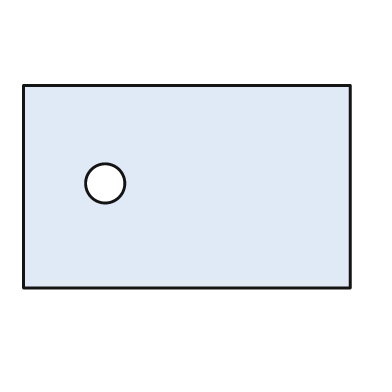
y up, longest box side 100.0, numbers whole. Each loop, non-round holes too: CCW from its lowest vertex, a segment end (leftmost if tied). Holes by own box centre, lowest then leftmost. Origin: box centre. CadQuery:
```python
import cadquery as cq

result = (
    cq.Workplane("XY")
    .moveTo(-50.0, -31.0)
    .lineTo(50.0, -31.0)
    .lineTo(50.0, 31.0)
    .lineTo(-50.0, 31.0)
    .close()
    .moveTo(-25.0, 1.0)
    .circle(6.0)
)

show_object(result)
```